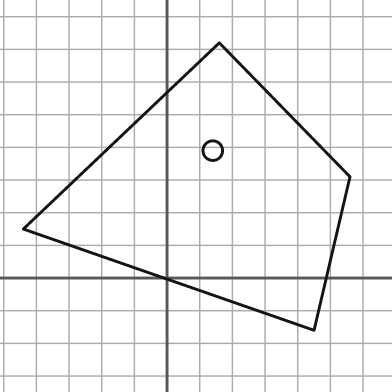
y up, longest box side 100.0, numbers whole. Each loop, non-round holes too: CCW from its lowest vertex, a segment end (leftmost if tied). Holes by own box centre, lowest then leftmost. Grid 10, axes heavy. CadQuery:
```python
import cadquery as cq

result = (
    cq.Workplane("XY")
    .moveTo(45.0, -16.0)
    .lineTo(56.0, 31.0)
    .lineTo(16.0, 72.0)
    .lineTo(-44.0, 15.0)
    .close()
    .moveTo(14.0, 39.0)
    .circle(3.0)
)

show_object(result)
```